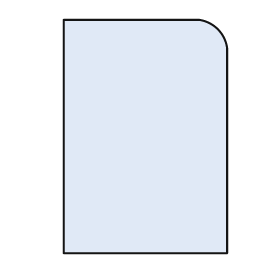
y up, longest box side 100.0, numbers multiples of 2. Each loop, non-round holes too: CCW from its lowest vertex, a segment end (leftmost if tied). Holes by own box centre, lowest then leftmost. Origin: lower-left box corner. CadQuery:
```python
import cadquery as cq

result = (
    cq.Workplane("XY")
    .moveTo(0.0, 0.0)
    .lineTo(70.0, 0.0)
    .lineTo(70.0, 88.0)
    .threePointArc((66.0, 96.0), (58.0, 100.0))
    .lineTo(0.0, 100.0)
    .close()
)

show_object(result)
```